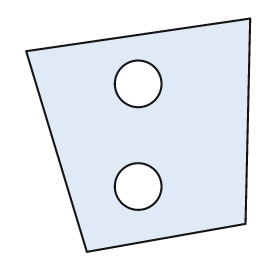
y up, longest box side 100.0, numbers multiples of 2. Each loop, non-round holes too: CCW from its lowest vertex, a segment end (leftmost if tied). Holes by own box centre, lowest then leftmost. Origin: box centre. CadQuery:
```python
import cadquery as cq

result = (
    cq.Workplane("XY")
    .moveTo(-22.0, -50.0)
    .lineTo(46.0, -38.0)
    .lineTo(48.0, 50.0)
    .lineTo(-48.0, 36.0)
    .close()
    .moveTo(0.0, -22.0)
    .circle(10.0)
    .moveTo(0.0, 22.0)
    .circle(10.0)
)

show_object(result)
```